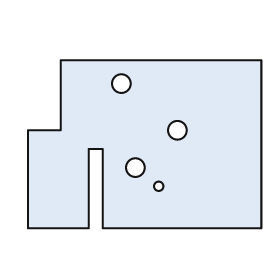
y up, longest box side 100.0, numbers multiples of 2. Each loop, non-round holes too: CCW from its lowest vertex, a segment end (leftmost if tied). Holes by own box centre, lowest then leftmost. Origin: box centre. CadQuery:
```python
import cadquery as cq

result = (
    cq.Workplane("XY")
    .moveTo(-50.0, -36.0)
    .lineTo(-24.0, -36.0)
    .lineTo(-24.0, -2.0)
    .lineTo(-18.0, -2.0)
    .lineTo(-18.0, -36.0)
    .lineTo(50.0, -36.0)
    .lineTo(50.0, 36.0)
    .lineTo(-36.0, 36.0)
    .lineTo(-36.0, 6.0)
    .lineTo(-50.0, 6.0)
    .close()
    .moveTo(6.0, -18.0)
    .circle(2.0)
    .moveTo(-4.0, -10.0)
    .circle(4.0)
    .moveTo(14.0, 6.0)
    .circle(4.0)
    .moveTo(-10.0, 26.0)
    .circle(4.0)
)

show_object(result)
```